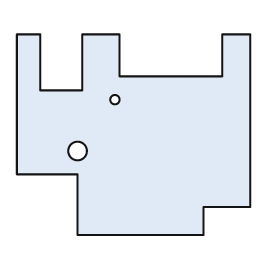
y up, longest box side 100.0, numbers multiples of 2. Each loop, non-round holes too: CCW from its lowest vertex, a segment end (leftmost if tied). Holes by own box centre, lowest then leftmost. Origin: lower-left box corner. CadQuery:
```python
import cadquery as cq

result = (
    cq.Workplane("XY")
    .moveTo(26.0, 0.0)
    .lineTo(80.0, 0.0)
    .lineTo(80.0, 12.0)
    .lineTo(100.0, 12.0)
    .lineTo(100.0, 86.0)
    .lineTo(88.0, 86.0)
    .lineTo(88.0, 68.0)
    .lineTo(44.0, 68.0)
    .lineTo(44.0, 86.0)
    .lineTo(28.0, 86.0)
    .lineTo(28.0, 62.0)
    .lineTo(10.0, 62.0)
    .lineTo(10.0, 86.0)
    .lineTo(0.0, 86.0)
    .lineTo(0.0, 26.0)
    .lineTo(26.0, 26.0)
    .close()
    .moveTo(26.0, 36.0)
    .circle(4.0)
    .moveTo(42.0, 58.0)
    .circle(2.0)
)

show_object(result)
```